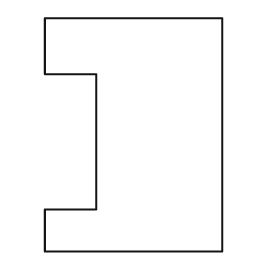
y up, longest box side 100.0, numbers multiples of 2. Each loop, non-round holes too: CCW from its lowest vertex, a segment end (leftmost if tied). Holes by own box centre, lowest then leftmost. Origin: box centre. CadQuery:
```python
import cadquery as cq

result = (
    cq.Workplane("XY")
    .moveTo(-38.0, -50.0)
    .lineTo(38.0, -50.0)
    .lineTo(38.0, 50.0)
    .lineTo(-38.0, 50.0)
    .lineTo(-38.0, 26.0)
    .lineTo(-16.0, 26.0)
    .lineTo(-16.0, -32.0)
    .lineTo(-38.0, -32.0)
    .close()
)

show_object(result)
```